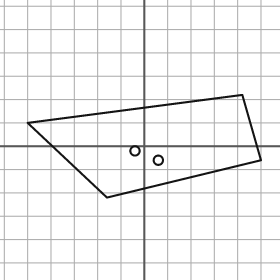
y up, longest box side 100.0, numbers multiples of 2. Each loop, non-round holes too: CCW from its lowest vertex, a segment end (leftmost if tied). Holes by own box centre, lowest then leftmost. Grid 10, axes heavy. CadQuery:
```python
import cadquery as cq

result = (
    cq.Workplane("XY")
    .moveTo(-16.0, -22.0)
    .lineTo(50.0, -6.0)
    .lineTo(42.0, 22.0)
    .lineTo(-50.0, 10.0)
    .close()
    .moveTo(6.0, -6.0)
    .circle(2.0)
    .moveTo(-4.0, -2.0)
    .circle(2.0)
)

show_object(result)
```